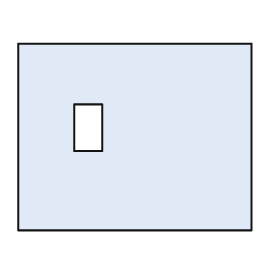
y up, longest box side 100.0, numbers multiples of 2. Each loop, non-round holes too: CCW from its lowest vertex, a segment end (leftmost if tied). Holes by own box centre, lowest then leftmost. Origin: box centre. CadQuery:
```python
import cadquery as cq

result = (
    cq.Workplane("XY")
    .moveTo(-50.0, -40.0)
    .lineTo(50.0, -40.0)
    .lineTo(50.0, 40.0)
    .lineTo(-50.0, 40.0)
    .close()
    .moveTo(-26.0, -6.0)
    .lineTo(-14.0, -6.0)
    .lineTo(-14.0, 14.0)
    .lineTo(-26.0, 14.0)
    .close()
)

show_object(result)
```